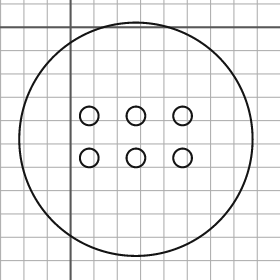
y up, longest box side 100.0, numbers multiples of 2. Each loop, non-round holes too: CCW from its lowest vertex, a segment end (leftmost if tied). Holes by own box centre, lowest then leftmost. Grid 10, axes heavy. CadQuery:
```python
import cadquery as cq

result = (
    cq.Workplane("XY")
    .moveTo(28.0, -48.0)
    .circle(50.0)
    .moveTo(8.0, -56.0)
    .circle(4.0)
    .moveTo(28.0, -56.0)
    .circle(4.0)
    .moveTo(48.0, -56.0)
    .circle(4.0)
    .moveTo(8.0, -38.0)
    .circle(4.0)
    .moveTo(28.0, -38.0)
    .circle(4.0)
    .moveTo(48.0, -38.0)
    .circle(4.0)
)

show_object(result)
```